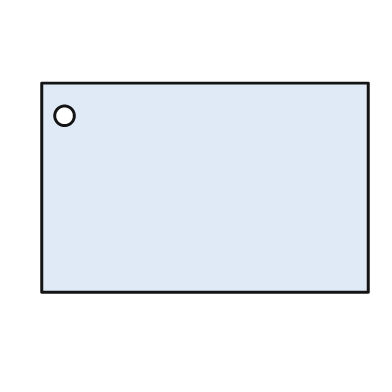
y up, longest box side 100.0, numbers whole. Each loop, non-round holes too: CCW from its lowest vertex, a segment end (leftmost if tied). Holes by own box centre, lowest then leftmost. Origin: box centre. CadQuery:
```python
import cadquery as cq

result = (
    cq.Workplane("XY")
    .moveTo(-50.0, -32.0)
    .lineTo(50.0, -32.0)
    .lineTo(50.0, 32.0)
    .lineTo(-50.0, 32.0)
    .close()
    .moveTo(-43.0, 22.0)
    .circle(3.0)
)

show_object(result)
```